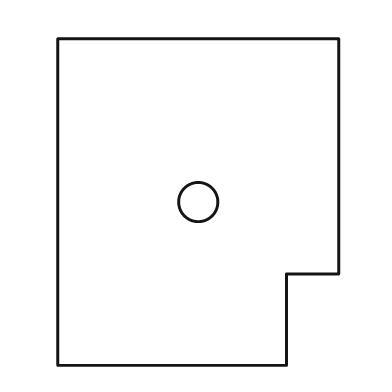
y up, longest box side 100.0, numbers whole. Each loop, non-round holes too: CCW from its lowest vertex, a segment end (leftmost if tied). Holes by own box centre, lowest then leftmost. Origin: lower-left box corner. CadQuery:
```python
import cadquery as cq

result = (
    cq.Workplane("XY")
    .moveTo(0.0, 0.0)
    .lineTo(70.0, 0.0)
    .lineTo(70.0, 28.0)
    .lineTo(86.0, 28.0)
    .lineTo(86.0, 100.0)
    .lineTo(0.0, 100.0)
    .close()
    .moveTo(43.0, 50.0)
    .circle(6.0)
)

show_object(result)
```